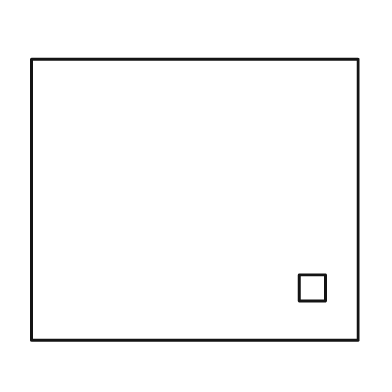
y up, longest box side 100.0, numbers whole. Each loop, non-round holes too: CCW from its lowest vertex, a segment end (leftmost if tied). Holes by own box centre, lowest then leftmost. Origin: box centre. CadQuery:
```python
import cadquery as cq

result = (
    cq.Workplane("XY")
    .moveTo(-50.0, -43.0)
    .lineTo(50.0, -43.0)
    .lineTo(50.0, 43.0)
    .lineTo(-50.0, 43.0)
    .close()
    .moveTo(32.0, -31.0)
    .lineTo(40.0, -31.0)
    .lineTo(40.0, -23.0)
    .lineTo(32.0, -23.0)
    .close()
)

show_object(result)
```